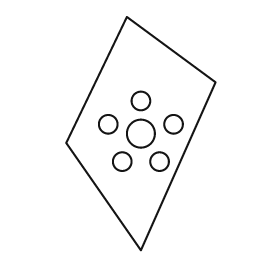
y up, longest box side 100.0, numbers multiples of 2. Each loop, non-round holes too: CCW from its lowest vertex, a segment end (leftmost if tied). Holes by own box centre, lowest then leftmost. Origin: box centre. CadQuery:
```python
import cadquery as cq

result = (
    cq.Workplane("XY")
    .moveTo(0.0, -50.0)
    .lineTo(32.0, 22.0)
    .lineTo(-6.0, 50.0)
    .lineTo(-32.0, -4.0)
    .close()
    .moveTo(-8.0, -12.0)
    .circle(4.0)
    .moveTo(8.0, -12.0)
    .circle(4.0)
    .moveTo(0.0, 0.0)
    .circle(6.0)
    .moveTo(-14.0, 4.0)
    .circle(4.0)
    .moveTo(14.0, 4.0)
    .circle(4.0)
    .moveTo(0.0, 14.0)
    .circle(4.0)
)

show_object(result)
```